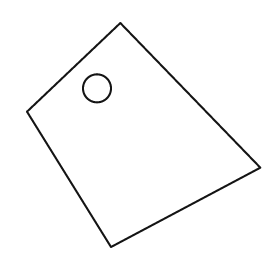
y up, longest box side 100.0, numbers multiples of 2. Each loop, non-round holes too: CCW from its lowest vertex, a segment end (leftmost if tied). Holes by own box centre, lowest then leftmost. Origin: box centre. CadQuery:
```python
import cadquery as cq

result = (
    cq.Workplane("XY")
    .moveTo(-14.0, -48.0)
    .lineTo(50.0, -14.0)
    .lineTo(-10.0, 48.0)
    .lineTo(-50.0, 10.0)
    .close()
    .moveTo(-20.0, 20.0)
    .circle(6.0)
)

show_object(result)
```